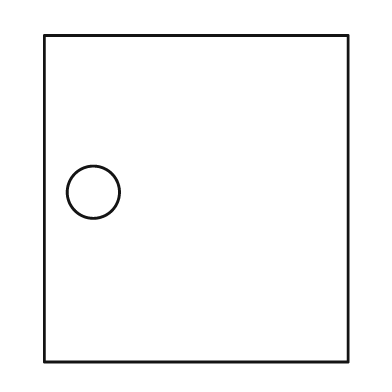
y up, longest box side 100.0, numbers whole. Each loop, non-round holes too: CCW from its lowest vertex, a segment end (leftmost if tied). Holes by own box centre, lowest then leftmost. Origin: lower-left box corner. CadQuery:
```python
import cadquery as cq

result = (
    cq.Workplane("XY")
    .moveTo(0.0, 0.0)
    .lineTo(93.0, 0.0)
    .lineTo(93.0, 100.0)
    .lineTo(0.0, 100.0)
    .close()
    .moveTo(15.0, 52.0)
    .circle(8.0)
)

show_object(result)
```